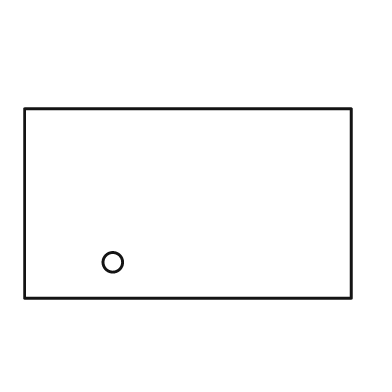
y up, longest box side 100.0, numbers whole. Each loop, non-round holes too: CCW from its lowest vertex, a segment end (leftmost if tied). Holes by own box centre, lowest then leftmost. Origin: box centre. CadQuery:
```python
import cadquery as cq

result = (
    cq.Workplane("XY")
    .moveTo(-50.0, -29.0)
    .lineTo(50.0, -29.0)
    .lineTo(50.0, 29.0)
    .lineTo(-50.0, 29.0)
    .close()
    .moveTo(-23.0, -18.0)
    .circle(3.0)
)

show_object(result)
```